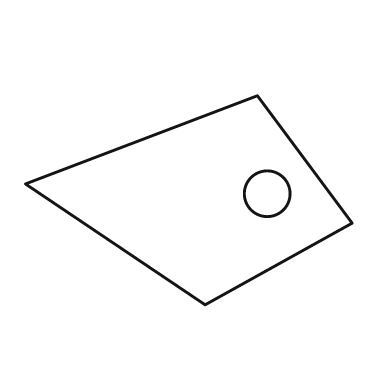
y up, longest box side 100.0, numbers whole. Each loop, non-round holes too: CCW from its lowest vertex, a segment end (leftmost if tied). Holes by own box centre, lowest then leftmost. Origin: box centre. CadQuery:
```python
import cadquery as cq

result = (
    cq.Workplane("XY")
    .moveTo(5.0, -32.0)
    .lineTo(50.0, -7.0)
    .lineTo(21.0, 32.0)
    .lineTo(-50.0, 5.0)
    .close()
    .moveTo(24.0, 2.0)
    .circle(7.0)
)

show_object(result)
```